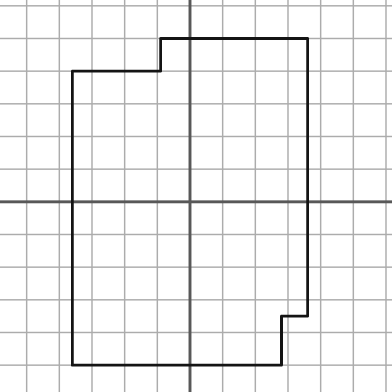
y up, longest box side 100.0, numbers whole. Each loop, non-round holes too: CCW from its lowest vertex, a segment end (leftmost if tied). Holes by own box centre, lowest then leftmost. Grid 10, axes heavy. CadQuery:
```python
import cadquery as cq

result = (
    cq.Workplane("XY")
    .moveTo(-36.0, -50.0)
    .lineTo(28.0, -50.0)
    .lineTo(28.0, -35.0)
    .lineTo(36.0, -35.0)
    .lineTo(36.0, 50.0)
    .lineTo(-9.0, 50.0)
    .lineTo(-9.0, 40.0)
    .lineTo(-36.0, 40.0)
    .close()
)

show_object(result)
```